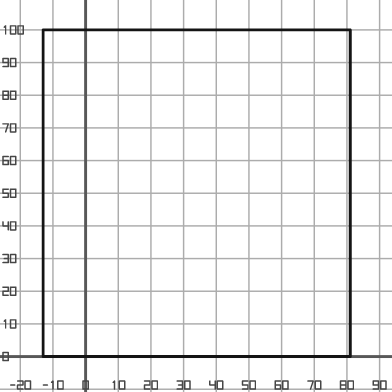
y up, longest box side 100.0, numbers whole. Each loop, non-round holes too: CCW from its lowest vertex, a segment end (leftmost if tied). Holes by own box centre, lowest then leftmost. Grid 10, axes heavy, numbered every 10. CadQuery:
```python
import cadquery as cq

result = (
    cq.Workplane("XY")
    .moveTo(-13.0, 0.0)
    .lineTo(81.0, 0.0)
    .lineTo(81.0, 100.0)
    .lineTo(-13.0, 100.0)
    .close()
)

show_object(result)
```